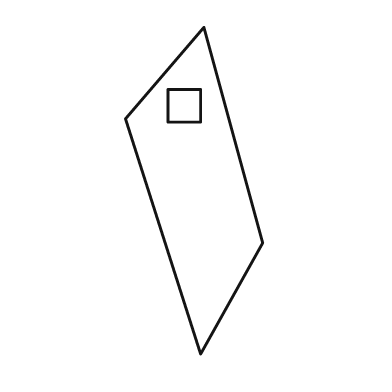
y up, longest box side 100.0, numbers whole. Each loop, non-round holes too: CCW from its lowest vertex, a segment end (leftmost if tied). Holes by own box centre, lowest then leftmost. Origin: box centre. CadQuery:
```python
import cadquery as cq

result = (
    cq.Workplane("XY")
    .moveTo(2.0, -50.0)
    .lineTo(21.0, -16.0)
    .lineTo(3.0, 50.0)
    .lineTo(-21.0, 22.0)
    .close()
    .moveTo(-8.0, 21.0)
    .lineTo(2.0, 21.0)
    .lineTo(2.0, 31.0)
    .lineTo(-8.0, 31.0)
    .close()
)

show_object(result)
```